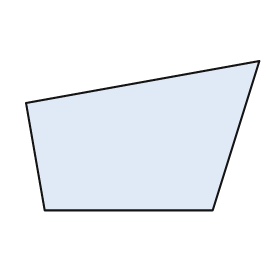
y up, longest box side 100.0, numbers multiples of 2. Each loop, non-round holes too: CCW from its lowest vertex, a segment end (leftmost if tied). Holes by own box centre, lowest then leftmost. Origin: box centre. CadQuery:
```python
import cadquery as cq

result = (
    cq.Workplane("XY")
    .moveTo(-42.0, -32.0)
    .lineTo(30.0, -32.0)
    .lineTo(50.0, 32.0)
    .lineTo(-50.0, 14.0)
    .close()
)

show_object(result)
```